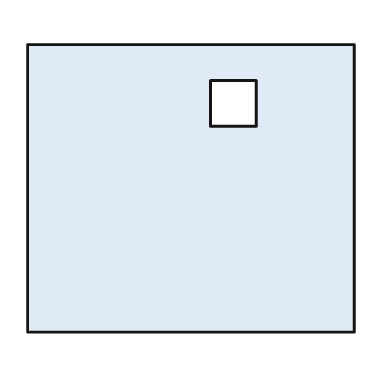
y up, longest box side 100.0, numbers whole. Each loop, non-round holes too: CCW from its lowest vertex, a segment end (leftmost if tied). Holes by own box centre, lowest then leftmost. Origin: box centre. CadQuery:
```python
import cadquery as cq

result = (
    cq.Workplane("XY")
    .moveTo(-50.0, -44.0)
    .lineTo(50.0, -44.0)
    .lineTo(50.0, 44.0)
    .lineTo(-50.0, 44.0)
    .close()
    .moveTo(6.0, 19.0)
    .lineTo(20.0, 19.0)
    .lineTo(20.0, 33.0)
    .lineTo(6.0, 33.0)
    .close()
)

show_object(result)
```